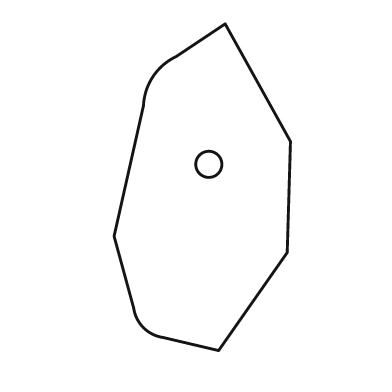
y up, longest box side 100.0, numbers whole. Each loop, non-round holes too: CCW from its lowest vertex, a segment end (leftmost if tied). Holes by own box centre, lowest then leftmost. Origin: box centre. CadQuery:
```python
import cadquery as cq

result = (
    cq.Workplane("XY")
    .moveTo(5.0, -50.0)
    .lineTo(26.0, -20.0)
    .lineTo(27.0, 14.0)
    .lineTo(7.0, 50.0)
    .lineTo(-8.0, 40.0)
    .threePointArc((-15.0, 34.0), (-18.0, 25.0))
    .lineTo(-27.0, -15.0)
    .lineTo(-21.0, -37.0)
    .threePointArc((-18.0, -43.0), (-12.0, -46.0))
    .close()
    .moveTo(2.0, 7.0)
    .circle(4.0)
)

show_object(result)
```